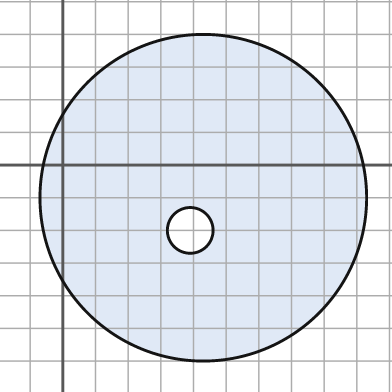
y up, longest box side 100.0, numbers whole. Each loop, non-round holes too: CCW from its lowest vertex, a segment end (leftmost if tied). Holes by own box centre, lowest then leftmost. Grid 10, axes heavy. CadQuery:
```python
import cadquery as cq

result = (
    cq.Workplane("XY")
    .moveTo(43.0, -10.0)
    .circle(50.0)
    .moveTo(39.0, -20.0)
    .circle(7.0)
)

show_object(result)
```